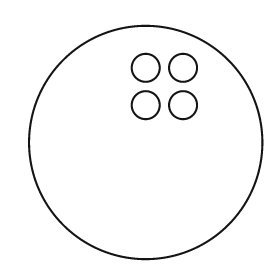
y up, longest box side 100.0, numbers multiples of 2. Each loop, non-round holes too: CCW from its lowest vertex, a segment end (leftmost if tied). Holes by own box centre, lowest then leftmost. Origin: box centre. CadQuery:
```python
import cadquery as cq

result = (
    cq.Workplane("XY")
    .moveTo(0.0, 0.0)
    .circle(50.0)
    .moveTo(0.0, 16.0)
    .circle(6.0)
    .moveTo(16.0, 16.0)
    .circle(6.0)
    .moveTo(0.0, 32.0)
    .circle(6.0)
    .moveTo(16.0, 32.0)
    .circle(6.0)
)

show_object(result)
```